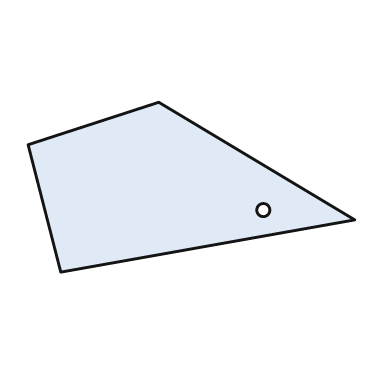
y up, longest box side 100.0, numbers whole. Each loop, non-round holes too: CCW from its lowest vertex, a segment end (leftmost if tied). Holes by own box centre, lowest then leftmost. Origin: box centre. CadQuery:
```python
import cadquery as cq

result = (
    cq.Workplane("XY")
    .moveTo(-40.0, -26.0)
    .lineTo(50.0, -10.0)
    .lineTo(-10.0, 26.0)
    .lineTo(-50.0, 13.0)
    .close()
    .moveTo(22.0, -7.0)
    .circle(2.0)
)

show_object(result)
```